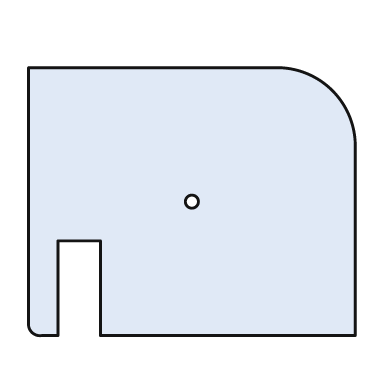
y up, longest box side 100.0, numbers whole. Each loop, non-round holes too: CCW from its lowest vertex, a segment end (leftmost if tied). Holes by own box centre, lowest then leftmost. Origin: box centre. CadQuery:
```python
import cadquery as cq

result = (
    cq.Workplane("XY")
    .moveTo(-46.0, -41.0)
    .lineTo(-41.0, -41.0)
    .lineTo(-41.0, -12.0)
    .lineTo(-28.0, -12.0)
    .lineTo(-28.0, -41.0)
    .lineTo(50.0, -41.0)
    .lineTo(50.0, 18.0)
    .threePointArc((43.0, 34.0), (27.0, 41.0))
    .lineTo(-50.0, 41.0)
    .lineTo(-50.0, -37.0)
    .threePointArc((-49.0, -40.0), (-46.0, -41.0))
    .close()
    .moveTo(0.0, 0.0)
    .circle(2.0)
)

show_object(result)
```